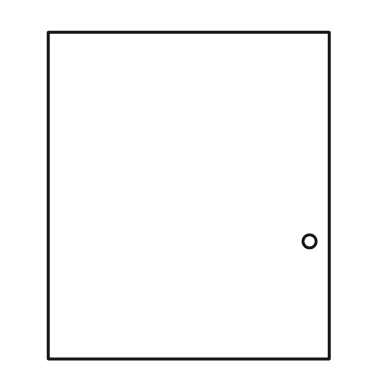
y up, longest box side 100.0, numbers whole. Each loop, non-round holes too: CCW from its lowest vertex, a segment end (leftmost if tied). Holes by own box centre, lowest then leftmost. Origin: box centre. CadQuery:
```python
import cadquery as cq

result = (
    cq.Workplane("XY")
    .moveTo(-43.0, -50.0)
    .lineTo(43.0, -50.0)
    .lineTo(43.0, 50.0)
    .lineTo(-43.0, 50.0)
    .close()
    .moveTo(37.0, -14.0)
    .circle(2.0)
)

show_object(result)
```